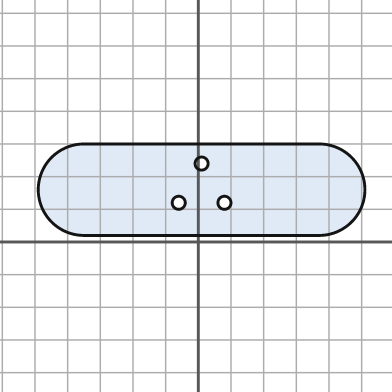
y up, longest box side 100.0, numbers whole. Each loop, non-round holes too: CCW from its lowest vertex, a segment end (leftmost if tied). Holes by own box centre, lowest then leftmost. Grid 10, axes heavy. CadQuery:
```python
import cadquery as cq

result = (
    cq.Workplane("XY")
    .moveTo(-35.0, 2.0)
    .lineTo(37.0, 2.0)
    .threePointArc((51.0, 16.0), (37.0, 30.0))
    .lineTo(-35.0, 30.0)
    .threePointArc((-49.0, 16.0), (-35.0, 2.0))
    .close()
    .moveTo(-6.0, 12.0)
    .circle(2.0)
    .moveTo(8.0, 12.0)
    .circle(2.0)
    .moveTo(1.0, 24.0)
    .circle(2.0)
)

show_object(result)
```